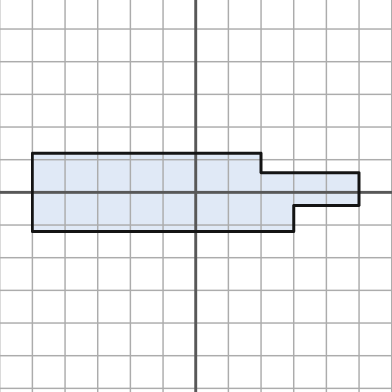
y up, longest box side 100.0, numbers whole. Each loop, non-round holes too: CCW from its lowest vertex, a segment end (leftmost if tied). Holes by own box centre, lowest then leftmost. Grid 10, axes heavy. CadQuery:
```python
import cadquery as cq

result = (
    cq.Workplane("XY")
    .moveTo(-50.0, -12.0)
    .lineTo(30.0, -12.0)
    .lineTo(30.0, -4.0)
    .lineTo(50.0, -4.0)
    .lineTo(50.0, 6.0)
    .lineTo(20.0, 6.0)
    .lineTo(20.0, 12.0)
    .lineTo(-50.0, 12.0)
    .close()
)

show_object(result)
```